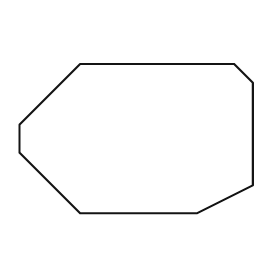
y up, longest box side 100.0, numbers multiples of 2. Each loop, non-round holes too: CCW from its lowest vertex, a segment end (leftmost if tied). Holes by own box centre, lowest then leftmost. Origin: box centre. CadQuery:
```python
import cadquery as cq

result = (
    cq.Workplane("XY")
    .moveTo(-24.0, -32.0)
    .lineTo(26.0, -32.0)
    .lineTo(50.0, -20.0)
    .lineTo(50.0, 24.0)
    .lineTo(42.0, 32.0)
    .lineTo(-24.0, 32.0)
    .lineTo(-50.0, 6.0)
    .lineTo(-50.0, -6.0)
    .close()
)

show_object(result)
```